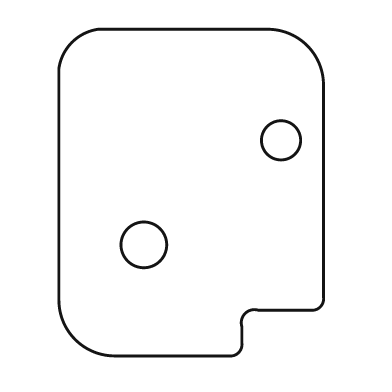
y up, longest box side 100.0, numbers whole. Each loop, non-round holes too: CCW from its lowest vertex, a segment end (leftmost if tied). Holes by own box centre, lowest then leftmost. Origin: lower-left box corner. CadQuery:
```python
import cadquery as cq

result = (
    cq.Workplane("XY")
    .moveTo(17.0, 0.0)
    .lineTo(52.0, 0.0)
    .threePointArc((55.0, 1.0), (56.0, 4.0))
    .lineTo(56.0, 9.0)
    .threePointArc((57.0, 13.0), (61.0, 14.0))
    .lineTo(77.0, 14.0)
    .threePointArc((80.0, 15.0), (81.0, 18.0))
    .lineTo(81.0, 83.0)
    .threePointArc((76.0, 95.0), (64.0, 100.0))
    .lineTo(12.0, 100.0)
    .threePointArc((4.0, 96.0), (0.0, 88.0))
    .lineTo(0.0, 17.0)
    .threePointArc((5.0, 5.0), (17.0, 0.0))
    .close()
    .moveTo(26.0, 34.0)
    .circle(7.0)
    .moveTo(68.0, 66.0)
    .circle(6.0)
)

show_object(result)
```